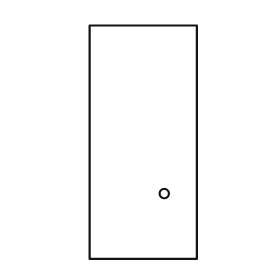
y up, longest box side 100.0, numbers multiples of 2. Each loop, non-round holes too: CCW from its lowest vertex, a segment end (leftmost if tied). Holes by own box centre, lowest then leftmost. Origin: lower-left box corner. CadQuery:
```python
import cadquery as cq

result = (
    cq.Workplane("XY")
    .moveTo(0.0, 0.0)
    .lineTo(46.0, 0.0)
    .lineTo(46.0, 100.0)
    .lineTo(0.0, 100.0)
    .close()
    .moveTo(32.0, 28.0)
    .circle(2.0)
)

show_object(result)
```